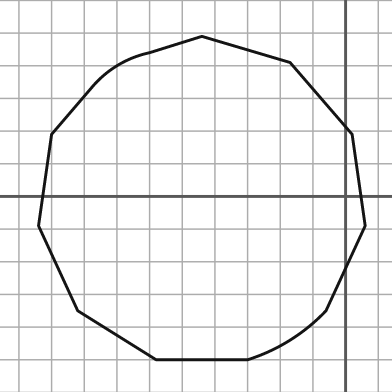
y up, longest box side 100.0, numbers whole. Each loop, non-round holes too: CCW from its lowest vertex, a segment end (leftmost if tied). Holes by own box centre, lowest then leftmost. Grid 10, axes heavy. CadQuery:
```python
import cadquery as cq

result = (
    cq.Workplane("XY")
    .moveTo(-58.0, -50.0)
    .lineTo(-30.0, -50.0)
    .threePointArc((-17.0, -44.0), (-6.0, -35.0))
    .lineTo(6.0, -9.0)
    .lineTo(2.0, 19.0)
    .lineTo(-17.0, 41.0)
    .lineTo(-44.0, 49.0)
    .lineTo(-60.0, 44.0)
    .threePointArc((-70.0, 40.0), (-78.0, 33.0))
    .lineTo(-90.0, 19.0)
    .lineTo(-94.0, -9.0)
    .lineTo(-82.0, -35.0)
    .close()
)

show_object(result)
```